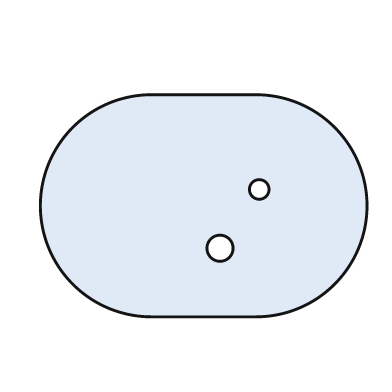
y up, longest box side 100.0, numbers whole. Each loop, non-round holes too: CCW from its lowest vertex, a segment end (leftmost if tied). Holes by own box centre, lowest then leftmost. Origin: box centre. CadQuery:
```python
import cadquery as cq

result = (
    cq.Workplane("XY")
    .moveTo(-16.0, -34.0)
    .lineTo(16.0, -34.0)
    .threePointArc((50.0, 0.0), (16.0, 34.0))
    .lineTo(-16.0, 34.0)
    .threePointArc((-50.0, 0.0), (-16.0, -34.0))
    .close()
    .moveTo(5.0, -13.0)
    .circle(4.0)
    .moveTo(17.0, 5.0)
    .circle(3.0)
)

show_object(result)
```